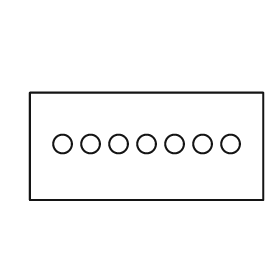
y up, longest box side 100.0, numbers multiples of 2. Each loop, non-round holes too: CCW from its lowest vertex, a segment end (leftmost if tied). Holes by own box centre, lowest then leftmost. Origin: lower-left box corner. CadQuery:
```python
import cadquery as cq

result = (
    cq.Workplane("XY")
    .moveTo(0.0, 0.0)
    .lineTo(100.0, 0.0)
    .lineTo(100.0, 46.0)
    .lineTo(0.0, 46.0)
    .close()
    .moveTo(14.0, 24.0)
    .circle(4.0)
    .moveTo(26.0, 24.0)
    .circle(4.0)
    .moveTo(38.0, 24.0)
    .circle(4.0)
    .moveTo(50.0, 24.0)
    .circle(4.0)
    .moveTo(62.0, 24.0)
    .circle(4.0)
    .moveTo(74.0, 24.0)
    .circle(4.0)
    .moveTo(86.0, 24.0)
    .circle(4.0)
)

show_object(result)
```